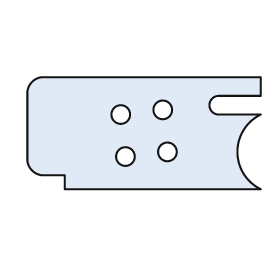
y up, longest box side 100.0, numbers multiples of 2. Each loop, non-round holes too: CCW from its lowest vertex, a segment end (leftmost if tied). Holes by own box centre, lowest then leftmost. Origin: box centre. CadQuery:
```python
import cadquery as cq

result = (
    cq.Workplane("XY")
    .moveTo(-34.0, -24.0)
    .lineTo(50.0, -24.0)
    .threePointArc((40.0, -8.0), (50.0, 8.0))
    .lineTo(32.0, 8.0)
    .threePointArc((28.0, 12.0), (32.0, 16.0))
    .lineTo(50.0, 16.0)
    .lineTo(50.0, 24.0)
    .lineTo(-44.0, 24.0)
    .threePointArc((-48.0, 22.0), (-50.0, 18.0))
    .lineTo(-50.0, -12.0)
    .threePointArc((-48.0, -16.0), (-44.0, -18.0))
    .lineTo(-34.0, -18.0)
    .close()
    .moveTo(-8.0, -10.0)
    .circle(4.0)
    .moveTo(10.0, -8.0)
    .circle(4.0)
    .moveTo(-10.0, 8.0)
    .circle(4.0)
    .moveTo(8.0, 10.0)
    .circle(4.0)
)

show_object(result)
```